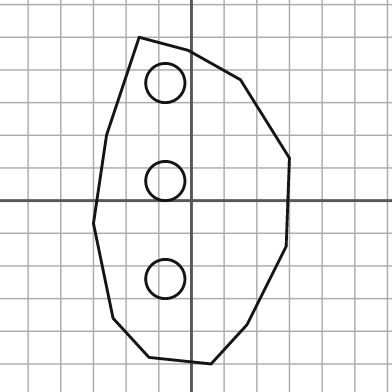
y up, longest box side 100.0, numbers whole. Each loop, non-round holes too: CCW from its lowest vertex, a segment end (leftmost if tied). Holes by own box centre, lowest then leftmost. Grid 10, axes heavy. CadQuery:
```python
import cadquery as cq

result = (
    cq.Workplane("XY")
    .moveTo(6.0, -50.0)
    .lineTo(17.0, -38.0)
    .lineTo(29.0, -14.0)
    .lineTo(30.0, 13.0)
    .lineTo(15.0, 37.0)
    .lineTo(-1.0, 46.0)
    .lineTo(-16.0, 50.0)
    .lineTo(-26.0, 20.0)
    .lineTo(-30.0, -7.0)
    .lineTo(-24.0, -36.0)
    .lineTo(-13.0, -48.0)
    .close()
    .moveTo(-8.0, -24.0)
    .circle(6.0)
    .moveTo(-8.0, 6.0)
    .circle(6.0)
    .moveTo(-8.0, 36.0)
    .circle(6.0)
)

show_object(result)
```